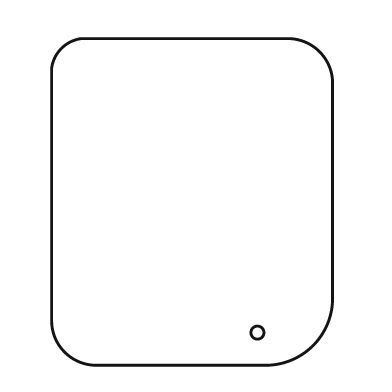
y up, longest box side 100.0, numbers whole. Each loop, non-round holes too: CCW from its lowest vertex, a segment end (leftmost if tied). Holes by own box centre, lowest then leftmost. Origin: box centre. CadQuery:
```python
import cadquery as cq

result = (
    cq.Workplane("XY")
    .moveTo(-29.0, -50.0)
    .lineTo(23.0, -50.0)
    .threePointArc((37.0, -44.0), (43.0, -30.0))
    .lineTo(43.0, 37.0)
    .threePointArc((39.0, 46.0), (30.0, 50.0))
    .lineTo(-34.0, 50.0)
    .threePointArc((-40.0, 47.0), (-43.0, 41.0))
    .lineTo(-43.0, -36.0)
    .threePointArc((-39.0, -46.0), (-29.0, -50.0))
    .close()
    .moveTo(20.0, -40.0)
    .circle(2.0)
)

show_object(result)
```